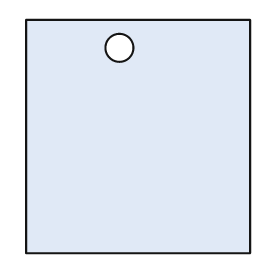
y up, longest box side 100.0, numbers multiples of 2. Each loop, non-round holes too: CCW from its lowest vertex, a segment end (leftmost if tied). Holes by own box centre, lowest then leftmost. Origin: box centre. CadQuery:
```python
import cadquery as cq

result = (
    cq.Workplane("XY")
    .moveTo(-48.0, -50.0)
    .lineTo(48.0, -50.0)
    .lineTo(48.0, 50.0)
    .lineTo(-48.0, 50.0)
    .close()
    .moveTo(-8.0, 38.0)
    .circle(6.0)
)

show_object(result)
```